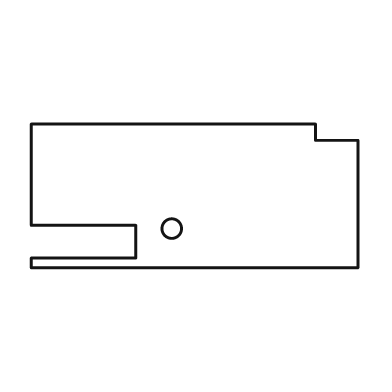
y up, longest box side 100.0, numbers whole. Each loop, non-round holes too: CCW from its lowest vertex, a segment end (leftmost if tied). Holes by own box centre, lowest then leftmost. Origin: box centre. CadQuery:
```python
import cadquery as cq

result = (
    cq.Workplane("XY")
    .moveTo(-50.0, -22.0)
    .lineTo(50.0, -22.0)
    .lineTo(50.0, 17.0)
    .lineTo(37.0, 17.0)
    .lineTo(37.0, 22.0)
    .lineTo(-50.0, 22.0)
    .lineTo(-50.0, -9.0)
    .lineTo(-18.0, -9.0)
    .lineTo(-18.0, -19.0)
    .lineTo(-50.0, -19.0)
    .close()
    .moveTo(-7.0, -10.0)
    .circle(3.0)
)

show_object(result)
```